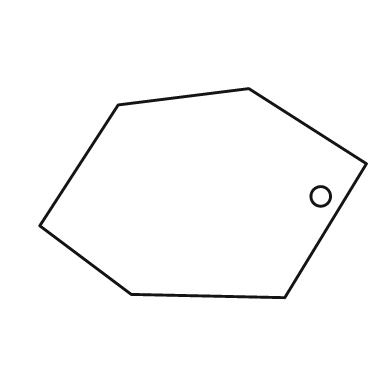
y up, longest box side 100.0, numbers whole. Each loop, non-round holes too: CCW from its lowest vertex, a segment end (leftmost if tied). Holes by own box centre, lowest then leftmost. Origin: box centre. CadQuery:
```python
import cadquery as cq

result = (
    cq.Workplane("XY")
    .moveTo(25.0, -32.0)
    .lineTo(50.0, 9.0)
    .lineTo(14.0, 32.0)
    .lineTo(-26.0, 27.0)
    .lineTo(-50.0, -10.0)
    .lineTo(-22.0, -31.0)
    .close()
    .moveTo(36.0, -1.0)
    .circle(3.0)
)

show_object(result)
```